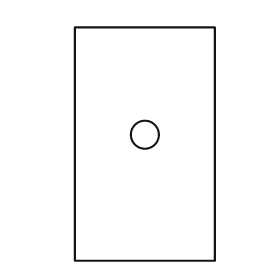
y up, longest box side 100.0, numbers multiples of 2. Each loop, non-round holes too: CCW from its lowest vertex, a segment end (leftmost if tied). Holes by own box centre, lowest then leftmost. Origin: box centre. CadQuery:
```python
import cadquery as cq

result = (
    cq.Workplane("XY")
    .moveTo(-30.0, -50.0)
    .lineTo(30.0, -50.0)
    .lineTo(30.0, 50.0)
    .lineTo(-30.0, 50.0)
    .close()
    .moveTo(0.0, 4.0)
    .circle(6.0)
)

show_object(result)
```